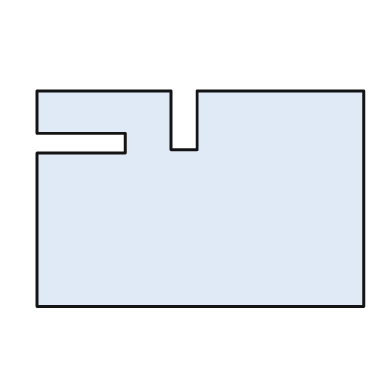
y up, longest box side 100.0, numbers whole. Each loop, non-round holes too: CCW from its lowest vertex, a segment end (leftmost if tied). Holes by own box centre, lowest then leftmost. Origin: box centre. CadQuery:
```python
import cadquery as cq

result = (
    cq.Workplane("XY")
    .moveTo(-50.0, -33.0)
    .lineTo(50.0, -33.0)
    .lineTo(50.0, 33.0)
    .lineTo(-1.0, 33.0)
    .lineTo(-1.0, 15.0)
    .lineTo(-9.0, 15.0)
    .lineTo(-9.0, 33.0)
    .lineTo(-50.0, 33.0)
    .lineTo(-50.0, 20.0)
    .lineTo(-23.0, 20.0)
    .lineTo(-23.0, 14.0)
    .lineTo(-50.0, 14.0)
    .close()
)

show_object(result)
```